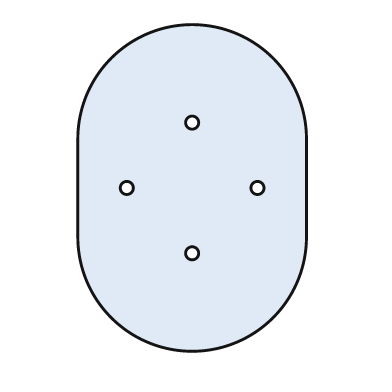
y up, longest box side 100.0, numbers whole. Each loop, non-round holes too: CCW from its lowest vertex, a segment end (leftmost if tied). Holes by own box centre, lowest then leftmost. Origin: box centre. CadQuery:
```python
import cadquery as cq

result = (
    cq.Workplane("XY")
    .moveTo(-35.0, -15.0)
    .threePointArc((0.0, -50.0), (35.0, -15.0))
    .lineTo(35.0, 15.0)
    .threePointArc((0.0, 50.0), (-35.0, 15.0))
    .close()
    .moveTo(0.0, -20.0)
    .circle(2.0)
    .moveTo(-20.0, 0.0)
    .circle(2.0)
    .moveTo(20.0, 0.0)
    .circle(2.0)
    .moveTo(0.0, 20.0)
    .circle(2.0)
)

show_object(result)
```